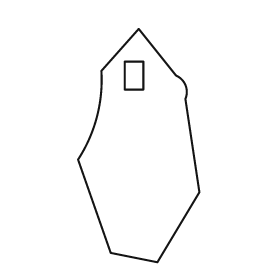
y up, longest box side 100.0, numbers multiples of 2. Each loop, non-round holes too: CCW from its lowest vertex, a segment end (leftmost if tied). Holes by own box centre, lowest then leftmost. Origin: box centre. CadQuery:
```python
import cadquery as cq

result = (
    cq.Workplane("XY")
    .moveTo(8.0, -50.0)
    .lineTo(26.0, -20.0)
    .lineTo(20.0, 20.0)
    .threePointArc((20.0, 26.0), (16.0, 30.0))
    .lineTo(0.0, 50.0)
    .lineTo(-16.0, 32.0)
    .threePointArc((-18.0, 12.0), (-26.0, -6.0))
    .lineTo(-12.0, -46.0)
    .close()
    .moveTo(-6.0, 24.0)
    .lineTo(2.0, 24.0)
    .lineTo(2.0, 36.0)
    .lineTo(-6.0, 36.0)
    .close()
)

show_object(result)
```